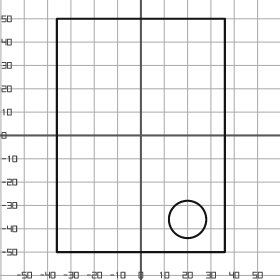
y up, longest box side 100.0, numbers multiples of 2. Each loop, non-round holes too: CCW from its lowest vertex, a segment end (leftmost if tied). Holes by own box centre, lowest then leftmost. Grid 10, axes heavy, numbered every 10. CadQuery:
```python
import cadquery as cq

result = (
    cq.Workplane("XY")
    .moveTo(-36.0, -50.0)
    .lineTo(36.0, -50.0)
    .lineTo(36.0, 50.0)
    .lineTo(-36.0, 50.0)
    .close()
    .moveTo(20.0, -36.0)
    .circle(8.0)
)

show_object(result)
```